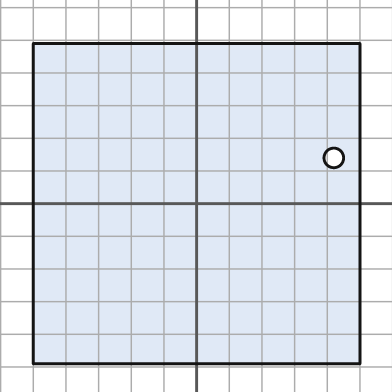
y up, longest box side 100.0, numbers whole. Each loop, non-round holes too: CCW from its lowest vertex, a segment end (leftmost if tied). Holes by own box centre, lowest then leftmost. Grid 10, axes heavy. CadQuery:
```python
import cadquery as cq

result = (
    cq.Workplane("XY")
    .moveTo(-50.0, -49.0)
    .lineTo(50.0, -49.0)
    .lineTo(50.0, 49.0)
    .lineTo(-50.0, 49.0)
    .close()
    .moveTo(42.0, 14.0)
    .circle(3.0)
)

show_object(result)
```